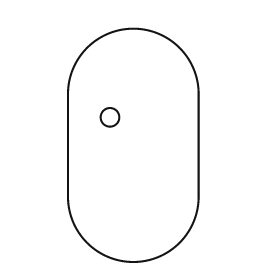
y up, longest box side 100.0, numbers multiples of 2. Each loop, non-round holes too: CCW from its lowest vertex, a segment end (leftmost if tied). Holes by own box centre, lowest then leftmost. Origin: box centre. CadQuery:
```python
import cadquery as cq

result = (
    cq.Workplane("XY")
    .moveTo(-28.0, -22.0)
    .threePointArc((0.0, -50.0), (28.0, -22.0))
    .lineTo(28.0, 22.0)
    .threePointArc((0.0, 50.0), (-28.0, 22.0))
    .close()
    .moveTo(-10.0, 12.0)
    .circle(4.0)
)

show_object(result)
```